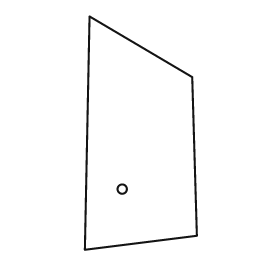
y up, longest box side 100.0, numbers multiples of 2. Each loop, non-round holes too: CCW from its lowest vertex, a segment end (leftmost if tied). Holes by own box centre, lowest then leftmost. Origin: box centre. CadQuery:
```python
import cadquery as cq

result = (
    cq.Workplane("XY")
    .moveTo(-24.0, -50.0)
    .lineTo(24.0, -44.0)
    .lineTo(22.0, 24.0)
    .lineTo(-22.0, 50.0)
    .close()
    .moveTo(-8.0, -24.0)
    .circle(2.0)
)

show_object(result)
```